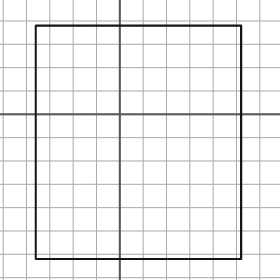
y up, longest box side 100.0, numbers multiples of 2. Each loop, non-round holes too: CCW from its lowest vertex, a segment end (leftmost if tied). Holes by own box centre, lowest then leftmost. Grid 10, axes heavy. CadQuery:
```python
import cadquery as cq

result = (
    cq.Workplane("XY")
    .moveTo(-36.0, -62.0)
    .lineTo(52.0, -62.0)
    .lineTo(52.0, 38.0)
    .lineTo(-36.0, 38.0)
    .close()
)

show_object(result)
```